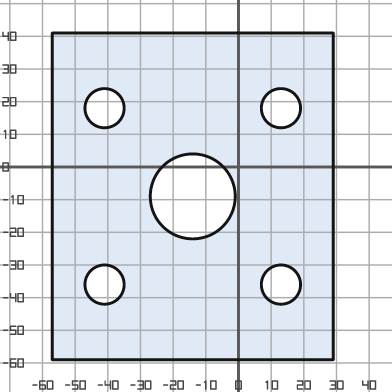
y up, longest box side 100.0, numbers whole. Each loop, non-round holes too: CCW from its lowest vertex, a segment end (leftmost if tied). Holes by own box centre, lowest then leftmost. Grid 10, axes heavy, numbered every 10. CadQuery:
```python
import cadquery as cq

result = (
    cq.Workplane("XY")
    .moveTo(-57.0, -59.0)
    .lineTo(29.0, -59.0)
    .lineTo(29.0, 41.0)
    .lineTo(-57.0, 41.0)
    .close()
    .moveTo(-41.0, -36.0)
    .circle(6.0)
    .moveTo(13.0, -36.0)
    .circle(6.0)
    .moveTo(-14.0, -9.0)
    .circle(13.0)
    .moveTo(-41.0, 18.0)
    .circle(6.0)
    .moveTo(13.0, 18.0)
    .circle(6.0)
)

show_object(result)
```